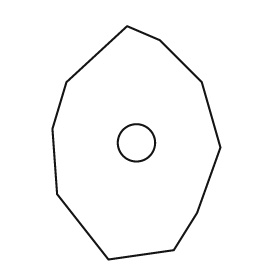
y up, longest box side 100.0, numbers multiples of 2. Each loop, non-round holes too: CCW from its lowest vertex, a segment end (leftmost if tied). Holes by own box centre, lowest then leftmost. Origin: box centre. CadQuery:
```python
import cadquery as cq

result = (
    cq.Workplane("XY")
    .moveTo(-12.0, -50.0)
    .lineTo(16.0, -46.0)
    .lineTo(26.0, -30.0)
    .lineTo(36.0, -2.0)
    .lineTo(28.0, 26.0)
    .lineTo(10.0, 44.0)
    .lineTo(-4.0, 50.0)
    .lineTo(-30.0, 26.0)
    .lineTo(-36.0, 6.0)
    .lineTo(-34.0, -22.0)
    .close()
    .moveTo(0.0, 0.0)
    .circle(8.0)
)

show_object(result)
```